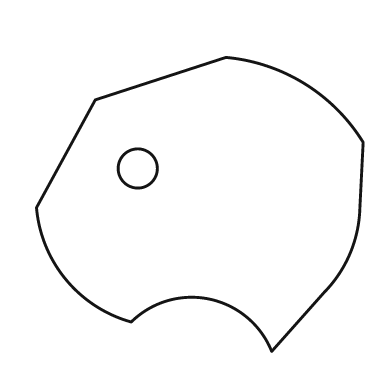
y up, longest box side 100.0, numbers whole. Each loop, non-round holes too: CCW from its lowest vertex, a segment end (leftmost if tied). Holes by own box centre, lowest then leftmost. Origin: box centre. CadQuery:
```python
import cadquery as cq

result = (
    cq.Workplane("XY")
    .moveTo(22.0, -45.0)
    .lineTo(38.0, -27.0)
    .threePointArc((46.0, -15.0), (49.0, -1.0))
    .lineTo(50.0, 19.0)
    .threePointArc((32.0, 37.0), (8.0, 45.0))
    .lineTo(-32.0, 32.0)
    .lineTo(-50.0, -1.0)
    .threePointArc((-41.0, -23.0), (-21.0, -36.0))
    .threePointArc((3.0, -29.0), (22.0, -45.0))
    .close()
    .moveTo(-19.0, 11.0)
    .circle(6.0)
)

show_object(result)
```